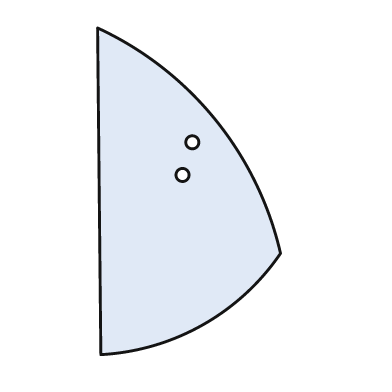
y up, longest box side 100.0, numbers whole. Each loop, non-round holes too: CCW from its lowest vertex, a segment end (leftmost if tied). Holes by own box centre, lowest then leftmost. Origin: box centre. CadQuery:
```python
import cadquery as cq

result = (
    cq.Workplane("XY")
    .moveTo(-27.0, -50.0)
    .threePointArc((4.0, -41.0), (28.0, -19.0))
    .threePointArc((8.0, 22.0), (-28.0, 50.0))
    .close()
    .moveTo(-2.0, 5.0)
    .circle(2.0)
    .moveTo(1.0, 15.0)
    .circle(2.0)
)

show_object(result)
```